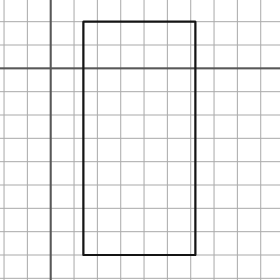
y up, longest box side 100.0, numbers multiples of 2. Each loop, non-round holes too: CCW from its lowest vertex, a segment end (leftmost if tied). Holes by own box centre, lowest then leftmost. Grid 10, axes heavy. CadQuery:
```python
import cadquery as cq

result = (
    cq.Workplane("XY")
    .moveTo(14.0, -80.0)
    .lineTo(62.0, -80.0)
    .lineTo(62.0, 20.0)
    .lineTo(14.0, 20.0)
    .close()
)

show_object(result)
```